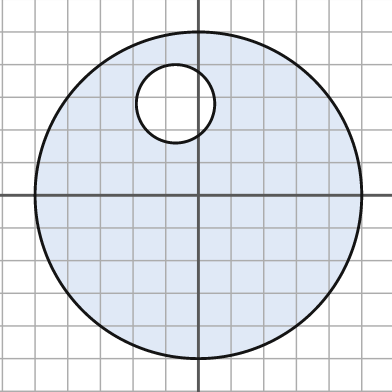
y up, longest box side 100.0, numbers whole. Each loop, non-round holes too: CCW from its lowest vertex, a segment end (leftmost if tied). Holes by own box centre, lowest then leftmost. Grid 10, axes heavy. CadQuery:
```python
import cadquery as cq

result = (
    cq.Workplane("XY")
    .moveTo(0.0, 0.0)
    .circle(50.0)
    .moveTo(-7.0, 28.0)
    .circle(12.0)
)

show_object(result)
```